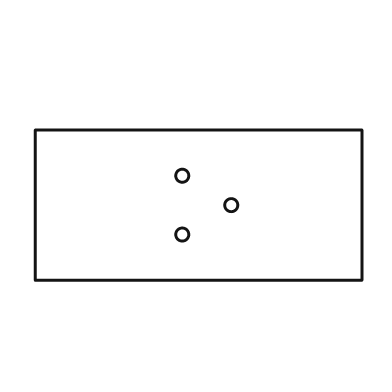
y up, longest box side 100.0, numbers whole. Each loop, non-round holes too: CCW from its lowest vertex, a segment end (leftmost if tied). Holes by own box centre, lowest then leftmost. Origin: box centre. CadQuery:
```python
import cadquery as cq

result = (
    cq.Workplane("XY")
    .moveTo(-50.0, -23.0)
    .lineTo(50.0, -23.0)
    .lineTo(50.0, 23.0)
    .lineTo(-50.0, 23.0)
    .close()
    .moveTo(-5.0, -9.0)
    .circle(2.0)
    .moveTo(10.0, 0.0)
    .circle(2.0)
    .moveTo(-5.0, 9.0)
    .circle(2.0)
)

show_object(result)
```